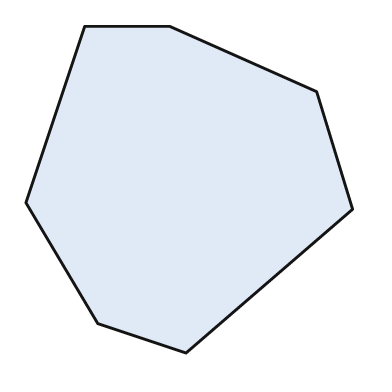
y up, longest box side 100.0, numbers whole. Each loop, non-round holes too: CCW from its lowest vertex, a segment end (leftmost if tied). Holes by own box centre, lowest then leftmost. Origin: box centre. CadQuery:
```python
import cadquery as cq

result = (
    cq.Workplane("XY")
    .moveTo(-1.0, -50.0)
    .lineTo(50.0, -6.0)
    .lineTo(39.0, 30.0)
    .lineTo(-6.0, 50.0)
    .lineTo(-32.0, 50.0)
    .lineTo(-50.0, -4.0)
    .lineTo(-28.0, -41.0)
    .close()
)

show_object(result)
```